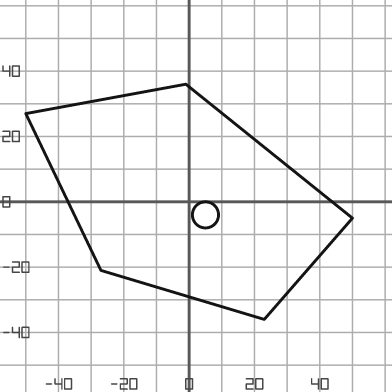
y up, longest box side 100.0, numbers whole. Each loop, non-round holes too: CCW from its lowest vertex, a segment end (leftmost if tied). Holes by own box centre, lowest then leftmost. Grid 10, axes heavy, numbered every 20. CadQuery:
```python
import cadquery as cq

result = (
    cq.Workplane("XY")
    .moveTo(23.0, -36.0)
    .lineTo(50.0, -5.0)
    .lineTo(-1.0, 36.0)
    .lineTo(-50.0, 27.0)
    .lineTo(-27.0, -21.0)
    .close()
    .moveTo(5.0, -4.0)
    .circle(4.0)
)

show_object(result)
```